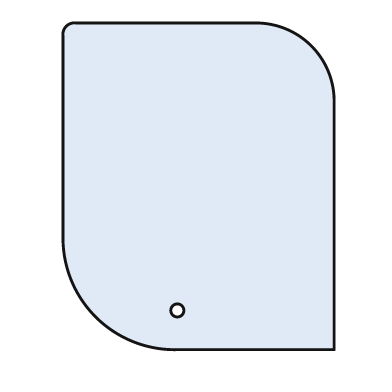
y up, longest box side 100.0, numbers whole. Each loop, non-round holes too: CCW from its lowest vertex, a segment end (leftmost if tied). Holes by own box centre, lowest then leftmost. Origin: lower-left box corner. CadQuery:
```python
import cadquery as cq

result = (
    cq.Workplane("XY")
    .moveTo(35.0, 0.0)
    .lineTo(83.0, 0.0)
    .lineTo(83.0, 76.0)
    .threePointArc((76.0, 93.0), (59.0, 100.0))
    .lineTo(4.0, 100.0)
    .threePointArc((1.0, 99.0), (0.0, 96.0))
    .lineTo(0.0, 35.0)
    .threePointArc((10.0, 10.0), (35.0, 0.0))
    .close()
    .moveTo(35.0, 12.0)
    .circle(2.0)
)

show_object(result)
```